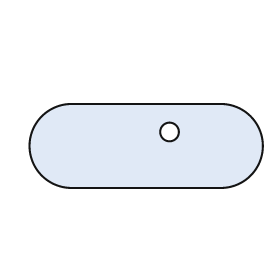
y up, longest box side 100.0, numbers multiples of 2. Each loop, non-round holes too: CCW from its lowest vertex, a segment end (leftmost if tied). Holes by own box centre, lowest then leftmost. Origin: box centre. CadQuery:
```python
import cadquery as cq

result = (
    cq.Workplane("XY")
    .moveTo(-32.0, -18.0)
    .lineTo(32.0, -18.0)
    .threePointArc((50.0, 0.0), (32.0, 18.0))
    .lineTo(-32.0, 18.0)
    .threePointArc((-50.0, 0.0), (-32.0, -18.0))
    .close()
    .moveTo(10.0, 6.0)
    .circle(4.0)
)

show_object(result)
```